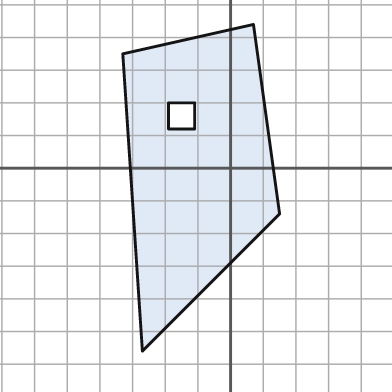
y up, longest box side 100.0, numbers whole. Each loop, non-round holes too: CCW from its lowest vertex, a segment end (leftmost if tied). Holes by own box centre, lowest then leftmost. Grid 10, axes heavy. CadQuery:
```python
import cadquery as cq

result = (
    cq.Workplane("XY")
    .moveTo(-27.0, -56.0)
    .lineTo(15.0, -14.0)
    .lineTo(7.0, 44.0)
    .lineTo(-33.0, 35.0)
    .close()
    .moveTo(-19.0, 12.0)
    .lineTo(-11.0, 12.0)
    .lineTo(-11.0, 20.0)
    .lineTo(-19.0, 20.0)
    .close()
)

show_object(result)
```